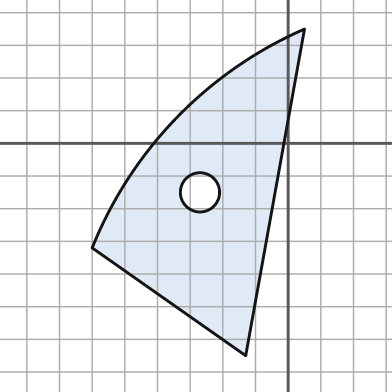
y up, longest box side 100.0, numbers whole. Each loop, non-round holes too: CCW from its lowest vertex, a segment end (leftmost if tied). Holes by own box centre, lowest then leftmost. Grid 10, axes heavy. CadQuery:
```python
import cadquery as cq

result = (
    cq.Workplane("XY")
    .moveTo(-13.0, -65.0)
    .lineTo(5.0, 35.0)
    .threePointArc((-34.0, 8.0), (-60.0, -32.0))
    .close()
    .moveTo(-27.0, -15.0)
    .circle(6.0)
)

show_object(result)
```